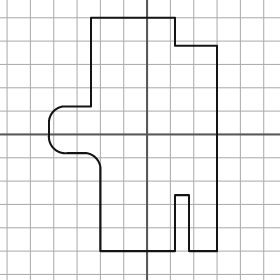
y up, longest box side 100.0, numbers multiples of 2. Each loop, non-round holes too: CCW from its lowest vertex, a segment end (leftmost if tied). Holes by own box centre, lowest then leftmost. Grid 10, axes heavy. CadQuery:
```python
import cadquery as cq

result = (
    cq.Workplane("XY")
    .moveTo(-20.0, -50.0)
    .lineTo(12.0, -50.0)
    .lineTo(12.0, -26.0)
    .lineTo(18.0, -26.0)
    .lineTo(18.0, -50.0)
    .lineTo(30.0, -50.0)
    .lineTo(30.0, 38.0)
    .lineTo(12.0, 38.0)
    .lineTo(12.0, 50.0)
    .lineTo(-24.0, 50.0)
    .lineTo(-24.0, 12.0)
    .lineTo(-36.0, 12.0)
    .threePointArc((-40.0, 10.0), (-42.0, 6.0))
    .lineTo(-42.0, 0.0)
    .threePointArc((-40.0, -6.0), (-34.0, -8.0))
    .lineTo(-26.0, -8.0)
    .threePointArc((-22.0, -10.0), (-20.0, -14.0))
    .close()
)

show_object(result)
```